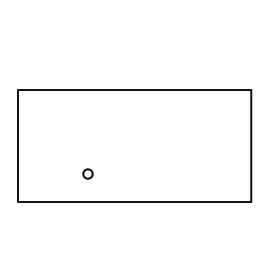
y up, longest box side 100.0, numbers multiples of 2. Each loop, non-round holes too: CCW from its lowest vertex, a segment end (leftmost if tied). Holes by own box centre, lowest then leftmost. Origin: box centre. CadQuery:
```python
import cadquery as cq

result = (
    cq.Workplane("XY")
    .moveTo(-50.0, -24.0)
    .lineTo(50.0, -24.0)
    .lineTo(50.0, 24.0)
    .lineTo(-50.0, 24.0)
    .close()
    .moveTo(-20.0, -12.0)
    .circle(2.0)
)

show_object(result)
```